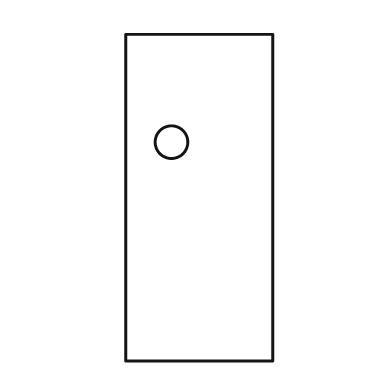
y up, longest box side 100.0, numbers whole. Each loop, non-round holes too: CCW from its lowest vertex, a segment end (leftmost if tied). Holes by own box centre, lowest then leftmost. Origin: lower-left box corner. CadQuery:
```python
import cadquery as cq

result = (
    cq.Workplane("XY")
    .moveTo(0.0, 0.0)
    .lineTo(45.0, 0.0)
    .lineTo(45.0, 100.0)
    .lineTo(0.0, 100.0)
    .close()
    .moveTo(14.0, 67.0)
    .circle(5.0)
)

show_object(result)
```